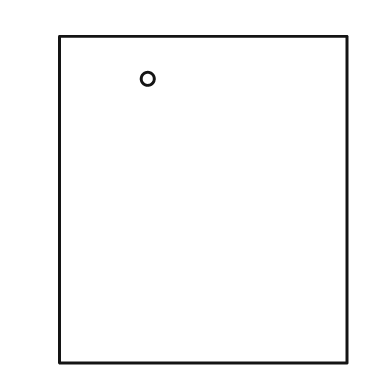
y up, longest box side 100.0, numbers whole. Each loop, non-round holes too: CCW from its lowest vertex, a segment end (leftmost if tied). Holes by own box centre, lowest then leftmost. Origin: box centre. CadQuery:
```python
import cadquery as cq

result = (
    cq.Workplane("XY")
    .moveTo(-44.0, -50.0)
    .lineTo(44.0, -50.0)
    .lineTo(44.0, 50.0)
    .lineTo(-44.0, 50.0)
    .close()
    .moveTo(-17.0, 37.0)
    .circle(2.0)
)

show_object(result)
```